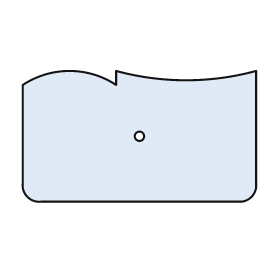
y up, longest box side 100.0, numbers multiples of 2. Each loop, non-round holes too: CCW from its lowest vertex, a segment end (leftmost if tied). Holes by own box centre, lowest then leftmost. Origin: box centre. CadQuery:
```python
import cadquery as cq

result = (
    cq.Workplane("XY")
    .moveTo(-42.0, -28.0)
    .lineTo(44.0, -28.0)
    .threePointArc((48.0, -26.0), (50.0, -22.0))
    .lineTo(50.0, 28.0)
    .threePointArc((20.0, 24.0), (-10.0, 28.0))
    .lineTo(-10.0, 22.0)
    .threePointArc((-30.0, 28.0), (-50.0, 22.0))
    .lineTo(-50.0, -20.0)
    .threePointArc((-48.0, -26.0), (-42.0, -28.0))
    .close()
    .moveTo(0.0, 0.0)
    .circle(2.0)
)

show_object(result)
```